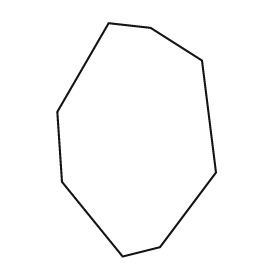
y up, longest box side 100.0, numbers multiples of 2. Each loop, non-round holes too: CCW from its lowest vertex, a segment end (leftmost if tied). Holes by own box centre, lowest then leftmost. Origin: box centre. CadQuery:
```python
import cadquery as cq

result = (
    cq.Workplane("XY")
    .moveTo(-6.0, -50.0)
    .lineTo(10.0, -46.0)
    .lineTo(34.0, -14.0)
    .lineTo(28.0, 34.0)
    .lineTo(6.0, 48.0)
    .lineTo(-12.0, 50.0)
    .lineTo(-34.0, 12.0)
    .lineTo(-32.0, -18.0)
    .close()
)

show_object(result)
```